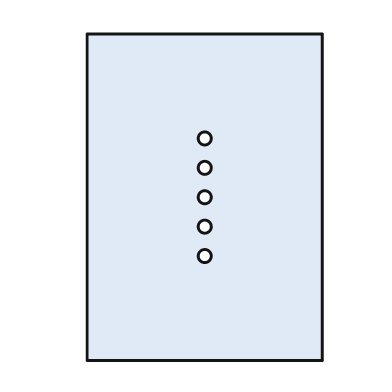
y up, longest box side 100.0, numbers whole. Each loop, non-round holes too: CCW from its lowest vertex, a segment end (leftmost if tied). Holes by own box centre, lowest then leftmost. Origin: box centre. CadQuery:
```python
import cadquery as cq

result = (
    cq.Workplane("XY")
    .moveTo(-36.0, -50.0)
    .lineTo(36.0, -50.0)
    .lineTo(36.0, 50.0)
    .lineTo(-36.0, 50.0)
    .close()
    .moveTo(0.0, -18.0)
    .circle(2.0)
    .moveTo(0.0, -9.0)
    .circle(2.0)
    .moveTo(0.0, 0.0)
    .circle(2.0)
    .moveTo(0.0, 9.0)
    .circle(2.0)
    .moveTo(0.0, 18.0)
    .circle(2.0)
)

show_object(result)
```